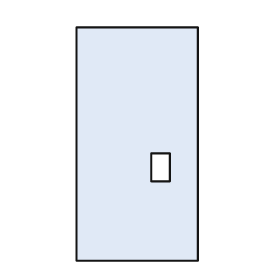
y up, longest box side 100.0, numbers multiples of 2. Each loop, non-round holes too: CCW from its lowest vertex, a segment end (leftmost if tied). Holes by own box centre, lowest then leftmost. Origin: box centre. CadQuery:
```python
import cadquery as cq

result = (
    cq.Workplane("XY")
    .moveTo(-26.0, -50.0)
    .lineTo(26.0, -50.0)
    .lineTo(26.0, 50.0)
    .lineTo(-26.0, 50.0)
    .close()
    .moveTo(6.0, -16.0)
    .lineTo(14.0, -16.0)
    .lineTo(14.0, -4.0)
    .lineTo(6.0, -4.0)
    .close()
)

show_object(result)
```